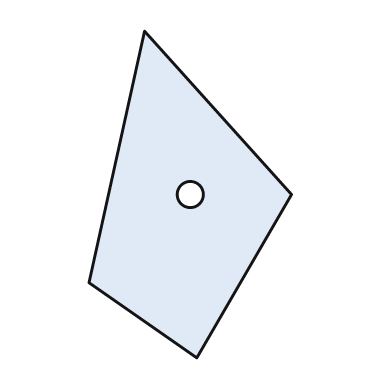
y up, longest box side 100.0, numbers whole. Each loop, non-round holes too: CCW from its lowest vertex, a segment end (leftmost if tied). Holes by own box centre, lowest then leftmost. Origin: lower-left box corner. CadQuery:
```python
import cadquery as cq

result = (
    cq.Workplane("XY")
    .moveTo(33.0, 0.0)
    .lineTo(62.0, 50.0)
    .lineTo(17.0, 100.0)
    .lineTo(0.0, 23.0)
    .close()
    .moveTo(31.0, 50.0)
    .circle(4.0)
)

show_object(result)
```